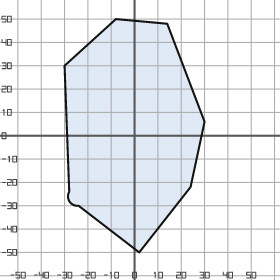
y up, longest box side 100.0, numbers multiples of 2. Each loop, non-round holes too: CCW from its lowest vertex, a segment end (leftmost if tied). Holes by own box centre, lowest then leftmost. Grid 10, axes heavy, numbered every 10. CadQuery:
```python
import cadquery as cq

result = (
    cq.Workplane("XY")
    .moveTo(2.0, -50.0)
    .lineTo(24.0, -22.0)
    .lineTo(30.0, 6.0)
    .lineTo(14.0, 48.0)
    .lineTo(-8.0, 50.0)
    .lineTo(-30.0, 30.0)
    .lineTo(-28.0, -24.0)
    .threePointArc((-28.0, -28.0), (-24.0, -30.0))
    .close()
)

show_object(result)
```